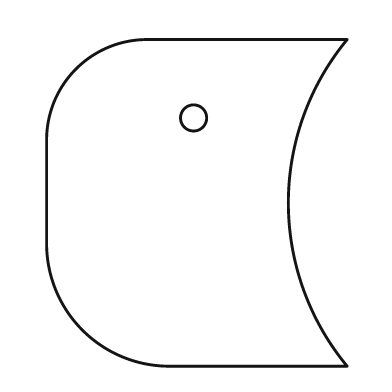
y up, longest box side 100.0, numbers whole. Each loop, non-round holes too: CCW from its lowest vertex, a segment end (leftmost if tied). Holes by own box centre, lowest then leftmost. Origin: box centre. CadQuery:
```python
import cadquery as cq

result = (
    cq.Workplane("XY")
    .moveTo(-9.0, -50.0)
    .lineTo(46.0, -50.0)
    .threePointArc((28.0, 0.0), (46.0, 50.0))
    .lineTo(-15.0, 50.0)
    .threePointArc((-37.0, 41.0), (-46.0, 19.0))
    .lineTo(-46.0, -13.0)
    .threePointArc((-35.0, -39.0), (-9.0, -50.0))
    .close()
    .moveTo(-1.0, 26.0)
    .circle(4.0)
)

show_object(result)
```